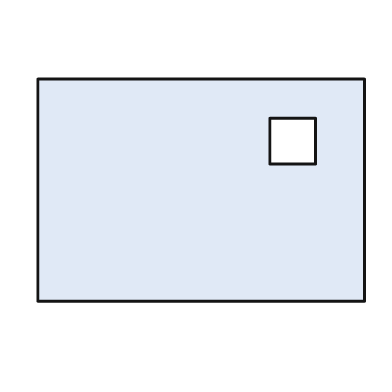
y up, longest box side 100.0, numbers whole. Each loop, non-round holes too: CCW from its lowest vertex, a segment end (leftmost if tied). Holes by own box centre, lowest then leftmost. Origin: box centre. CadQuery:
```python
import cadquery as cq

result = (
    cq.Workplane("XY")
    .moveTo(-50.0, -34.0)
    .lineTo(50.0, -34.0)
    .lineTo(50.0, 34.0)
    .lineTo(-50.0, 34.0)
    .close()
    .moveTo(21.0, 8.0)
    .lineTo(35.0, 8.0)
    .lineTo(35.0, 22.0)
    .lineTo(21.0, 22.0)
    .close()
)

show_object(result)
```